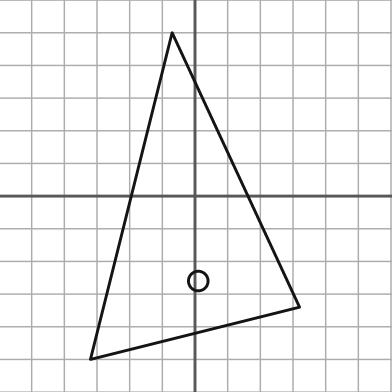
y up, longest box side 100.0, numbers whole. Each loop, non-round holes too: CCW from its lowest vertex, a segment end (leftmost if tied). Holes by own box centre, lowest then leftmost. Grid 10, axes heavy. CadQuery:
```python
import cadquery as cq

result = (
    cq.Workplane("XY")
    .moveTo(-32.0, -50.0)
    .lineTo(32.0, -34.0)
    .lineTo(-7.0, 50.0)
    .close()
    .moveTo(1.0, -26.0)
    .circle(3.0)
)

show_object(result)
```